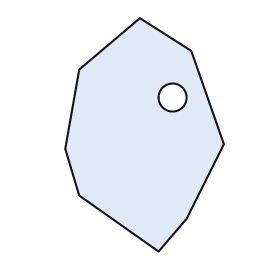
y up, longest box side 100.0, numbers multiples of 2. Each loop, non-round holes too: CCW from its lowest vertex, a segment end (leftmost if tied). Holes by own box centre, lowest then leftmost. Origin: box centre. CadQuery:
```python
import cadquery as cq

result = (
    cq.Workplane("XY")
    .moveTo(6.0, -50.0)
    .lineTo(18.0, -36.0)
    .lineTo(34.0, -4.0)
    .lineTo(20.0, 36.0)
    .lineTo(-2.0, 50.0)
    .lineTo(-28.0, 28.0)
    .lineTo(-34.0, -6.0)
    .lineTo(-28.0, -26.0)
    .close()
    .moveTo(12.0, 16.0)
    .circle(6.0)
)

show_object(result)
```